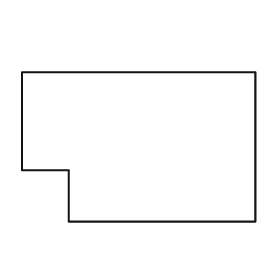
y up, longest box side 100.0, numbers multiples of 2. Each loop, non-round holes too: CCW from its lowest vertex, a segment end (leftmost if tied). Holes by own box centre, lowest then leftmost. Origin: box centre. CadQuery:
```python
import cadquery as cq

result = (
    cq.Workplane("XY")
    .moveTo(-30.0, -32.0)
    .lineTo(50.0, -32.0)
    .lineTo(50.0, 32.0)
    .lineTo(-50.0, 32.0)
    .lineTo(-50.0, -10.0)
    .lineTo(-30.0, -10.0)
    .close()
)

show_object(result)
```